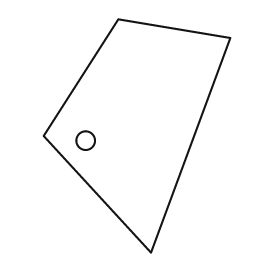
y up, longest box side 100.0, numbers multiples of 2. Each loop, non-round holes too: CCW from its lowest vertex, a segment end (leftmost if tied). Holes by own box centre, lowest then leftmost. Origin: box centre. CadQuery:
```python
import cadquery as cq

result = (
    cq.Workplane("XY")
    .moveTo(6.0, -50.0)
    .lineTo(40.0, 42.0)
    .lineTo(-8.0, 50.0)
    .lineTo(-40.0, 0.0)
    .close()
    .moveTo(-22.0, -2.0)
    .circle(4.0)
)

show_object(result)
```